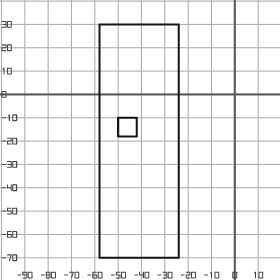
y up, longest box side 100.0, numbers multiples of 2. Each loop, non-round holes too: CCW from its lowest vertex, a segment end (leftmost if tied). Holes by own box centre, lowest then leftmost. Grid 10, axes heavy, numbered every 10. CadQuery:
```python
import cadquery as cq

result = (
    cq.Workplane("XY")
    .moveTo(-58.0, -70.0)
    .lineTo(-24.0, -70.0)
    .lineTo(-24.0, 30.0)
    .lineTo(-58.0, 30.0)
    .close()
    .moveTo(-50.0, -18.0)
    .lineTo(-42.0, -18.0)
    .lineTo(-42.0, -10.0)
    .lineTo(-50.0, -10.0)
    .close()
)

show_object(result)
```